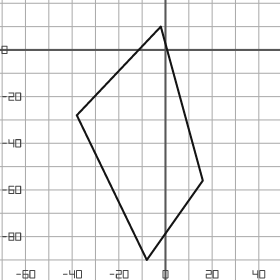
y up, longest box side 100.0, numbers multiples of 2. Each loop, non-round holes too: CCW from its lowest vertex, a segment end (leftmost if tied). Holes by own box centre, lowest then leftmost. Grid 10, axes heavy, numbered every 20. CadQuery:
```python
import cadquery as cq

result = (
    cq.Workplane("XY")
    .moveTo(-8.0, -90.0)
    .lineTo(16.0, -56.0)
    .lineTo(-2.0, 10.0)
    .lineTo(-38.0, -28.0)
    .close()
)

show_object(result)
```